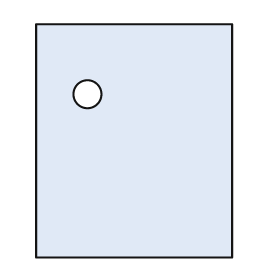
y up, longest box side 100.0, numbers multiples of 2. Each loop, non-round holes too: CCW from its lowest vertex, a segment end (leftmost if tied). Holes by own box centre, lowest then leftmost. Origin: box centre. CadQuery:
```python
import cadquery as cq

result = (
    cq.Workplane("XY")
    .moveTo(-42.0, -50.0)
    .lineTo(42.0, -50.0)
    .lineTo(42.0, 50.0)
    .lineTo(-42.0, 50.0)
    .close()
    .moveTo(-20.0, 20.0)
    .circle(6.0)
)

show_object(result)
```